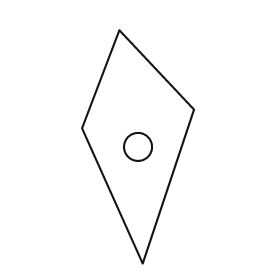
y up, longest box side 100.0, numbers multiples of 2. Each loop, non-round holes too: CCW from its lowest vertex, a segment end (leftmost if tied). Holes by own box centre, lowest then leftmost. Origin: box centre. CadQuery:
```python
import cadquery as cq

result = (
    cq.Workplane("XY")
    .moveTo(2.0, -50.0)
    .lineTo(24.0, 16.0)
    .lineTo(-8.0, 50.0)
    .lineTo(-24.0, 8.0)
    .close()
    .moveTo(0.0, 0.0)
    .circle(6.0)
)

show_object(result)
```